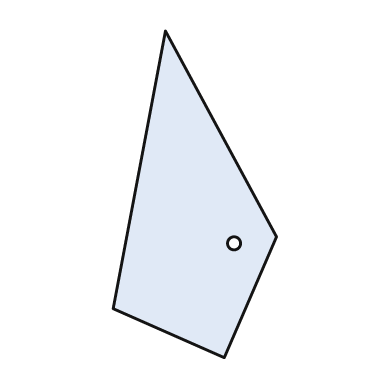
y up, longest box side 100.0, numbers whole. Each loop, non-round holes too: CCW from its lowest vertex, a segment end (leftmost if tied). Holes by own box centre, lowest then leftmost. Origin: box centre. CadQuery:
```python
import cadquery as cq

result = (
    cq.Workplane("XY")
    .moveTo(9.0, -50.0)
    .lineTo(25.0, -13.0)
    .lineTo(-9.0, 50.0)
    .lineTo(-25.0, -35.0)
    .close()
    .moveTo(12.0, -15.0)
    .circle(2.0)
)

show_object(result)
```